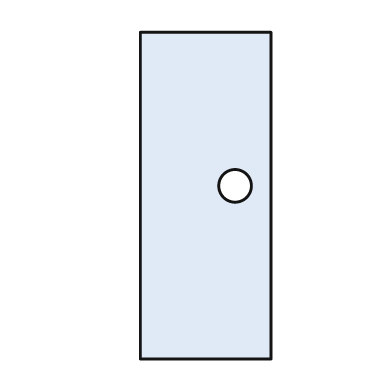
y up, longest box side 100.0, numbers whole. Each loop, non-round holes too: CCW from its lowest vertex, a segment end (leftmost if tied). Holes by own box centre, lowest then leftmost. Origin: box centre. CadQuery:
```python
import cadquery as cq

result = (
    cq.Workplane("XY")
    .moveTo(-20.0, -50.0)
    .lineTo(20.0, -50.0)
    .lineTo(20.0, 50.0)
    .lineTo(-20.0, 50.0)
    .close()
    .moveTo(9.0, 3.0)
    .circle(5.0)
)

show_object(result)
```